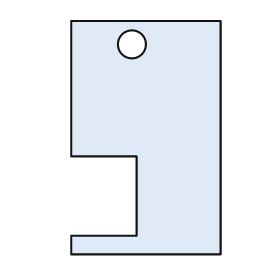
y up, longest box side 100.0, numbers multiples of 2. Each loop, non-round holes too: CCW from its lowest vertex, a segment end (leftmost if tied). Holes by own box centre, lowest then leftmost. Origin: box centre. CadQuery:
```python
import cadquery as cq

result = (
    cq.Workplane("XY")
    .moveTo(-32.0, -50.0)
    .lineTo(32.0, -50.0)
    .lineTo(32.0, 50.0)
    .lineTo(-32.0, 50.0)
    .lineTo(-32.0, -8.0)
    .lineTo(-4.0, -8.0)
    .lineTo(-4.0, -42.0)
    .lineTo(-32.0, -42.0)
    .close()
    .moveTo(-6.0, 40.0)
    .circle(6.0)
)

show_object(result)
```